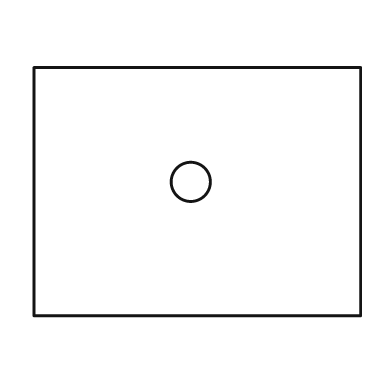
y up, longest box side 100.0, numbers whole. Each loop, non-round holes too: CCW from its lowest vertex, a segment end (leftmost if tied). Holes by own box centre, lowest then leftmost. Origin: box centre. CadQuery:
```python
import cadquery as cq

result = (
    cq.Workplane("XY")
    .moveTo(-50.0, -38.0)
    .lineTo(50.0, -38.0)
    .lineTo(50.0, 38.0)
    .lineTo(-50.0, 38.0)
    .close()
    .moveTo(-2.0, 3.0)
    .circle(6.0)
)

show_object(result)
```